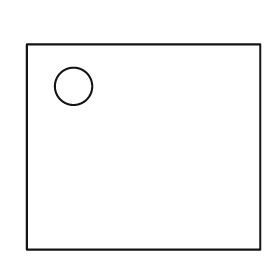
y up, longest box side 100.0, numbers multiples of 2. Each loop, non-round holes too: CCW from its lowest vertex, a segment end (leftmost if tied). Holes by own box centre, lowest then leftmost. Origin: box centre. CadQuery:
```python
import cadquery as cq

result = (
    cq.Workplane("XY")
    .moveTo(-50.0, -44.0)
    .lineTo(50.0, -44.0)
    .lineTo(50.0, 44.0)
    .lineTo(-50.0, 44.0)
    .close()
    .moveTo(-30.0, 26.0)
    .circle(8.0)
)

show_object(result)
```